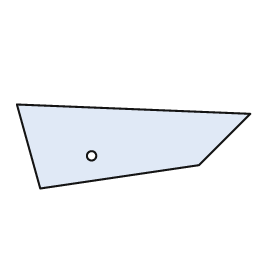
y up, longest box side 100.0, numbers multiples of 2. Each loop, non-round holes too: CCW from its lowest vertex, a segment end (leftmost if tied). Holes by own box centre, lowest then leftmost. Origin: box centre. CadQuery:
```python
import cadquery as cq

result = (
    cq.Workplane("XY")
    .moveTo(-40.0, -18.0)
    .lineTo(28.0, -8.0)
    .lineTo(50.0, 14.0)
    .lineTo(-50.0, 18.0)
    .close()
    .moveTo(-18.0, -4.0)
    .circle(2.0)
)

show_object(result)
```